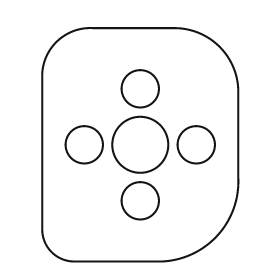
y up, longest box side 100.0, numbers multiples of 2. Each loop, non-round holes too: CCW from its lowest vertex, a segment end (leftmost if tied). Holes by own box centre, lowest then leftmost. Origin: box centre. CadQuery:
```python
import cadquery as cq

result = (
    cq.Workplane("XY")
    .moveTo(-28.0, -50.0)
    .lineTo(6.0, -50.0)
    .threePointArc((32.0, -40.0), (42.0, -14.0))
    .lineTo(42.0, 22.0)
    .threePointArc((34.0, 42.0), (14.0, 50.0))
    .lineTo(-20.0, 50.0)
    .threePointArc((-36.0, 44.0), (-42.0, 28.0))
    .lineTo(-42.0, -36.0)
    .threePointArc((-38.0, -46.0), (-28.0, -50.0))
    .close()
    .moveTo(0.0, -24.0)
    .circle(8.0)
    .moveTo(-24.0, 0.0)
    .circle(8.0)
    .moveTo(0.0, 0.0)
    .circle(12.0)
    .moveTo(24.0, 0.0)
    .circle(8.0)
    .moveTo(0.0, 24.0)
    .circle(8.0)
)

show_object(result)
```